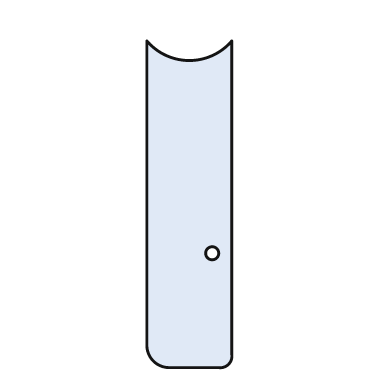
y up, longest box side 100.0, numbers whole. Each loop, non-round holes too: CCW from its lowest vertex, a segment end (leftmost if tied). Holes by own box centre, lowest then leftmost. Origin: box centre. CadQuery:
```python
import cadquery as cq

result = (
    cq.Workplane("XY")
    .moveTo(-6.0, -50.0)
    .lineTo(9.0, -50.0)
    .threePointArc((12.0, -49.0), (13.0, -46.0))
    .lineTo(13.0, 50.0)
    .threePointArc((0.0, 44.0), (-13.0, 50.0))
    .lineTo(-13.0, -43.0)
    .threePointArc((-11.0, -48.0), (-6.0, -50.0))
    .close()
    .moveTo(7.0, -15.0)
    .circle(2.0)
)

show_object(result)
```